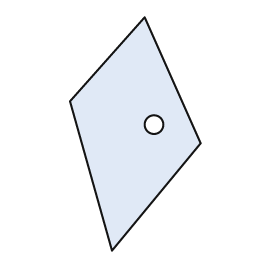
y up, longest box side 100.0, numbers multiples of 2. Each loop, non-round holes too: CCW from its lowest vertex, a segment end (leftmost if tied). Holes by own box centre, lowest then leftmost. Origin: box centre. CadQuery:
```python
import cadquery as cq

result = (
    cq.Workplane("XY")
    .moveTo(-10.0, -50.0)
    .lineTo(28.0, -4.0)
    .lineTo(4.0, 50.0)
    .lineTo(-28.0, 14.0)
    .close()
    .moveTo(8.0, 4.0)
    .circle(4.0)
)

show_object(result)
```